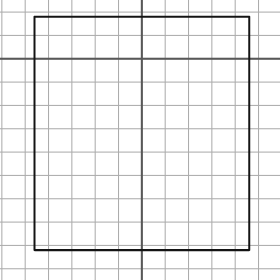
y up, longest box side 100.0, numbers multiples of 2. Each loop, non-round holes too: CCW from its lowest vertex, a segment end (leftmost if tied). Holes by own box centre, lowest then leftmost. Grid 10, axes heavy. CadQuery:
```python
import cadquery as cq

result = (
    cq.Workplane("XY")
    .moveTo(-46.0, -82.0)
    .lineTo(46.0, -82.0)
    .lineTo(46.0, 18.0)
    .lineTo(-46.0, 18.0)
    .close()
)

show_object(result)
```